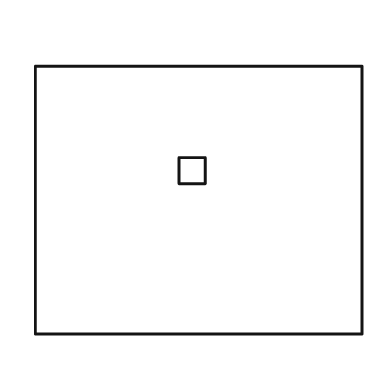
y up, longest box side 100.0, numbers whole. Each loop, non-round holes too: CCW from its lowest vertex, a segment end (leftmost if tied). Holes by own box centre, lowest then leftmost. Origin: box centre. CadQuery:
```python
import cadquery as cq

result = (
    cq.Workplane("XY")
    .moveTo(-50.0, -41.0)
    .lineTo(50.0, -41.0)
    .lineTo(50.0, 41.0)
    .lineTo(-50.0, 41.0)
    .close()
    .moveTo(-6.0, 5.0)
    .lineTo(2.0, 5.0)
    .lineTo(2.0, 13.0)
    .lineTo(-6.0, 13.0)
    .close()
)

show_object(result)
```